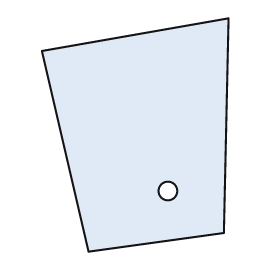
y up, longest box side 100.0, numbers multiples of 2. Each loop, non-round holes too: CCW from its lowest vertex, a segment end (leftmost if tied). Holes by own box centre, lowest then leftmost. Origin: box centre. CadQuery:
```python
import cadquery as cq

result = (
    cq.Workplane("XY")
    .moveTo(-20.0, -50.0)
    .lineTo(38.0, -42.0)
    .lineTo(40.0, 50.0)
    .lineTo(-40.0, 36.0)
    .close()
    .moveTo(14.0, -24.0)
    .circle(4.0)
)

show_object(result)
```